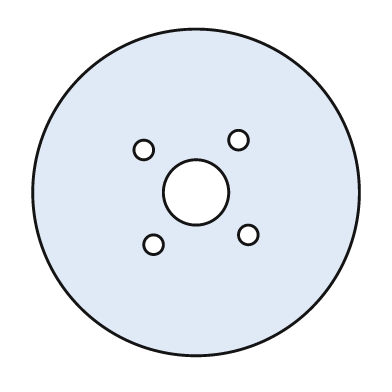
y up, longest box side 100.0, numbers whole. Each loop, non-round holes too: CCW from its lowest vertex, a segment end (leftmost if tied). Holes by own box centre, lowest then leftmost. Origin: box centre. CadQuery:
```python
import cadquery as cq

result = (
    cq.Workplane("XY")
    .moveTo(0.0, 0.0)
    .circle(50.0)
    .moveTo(-13.0, -16.0)
    .circle(3.0)
    .moveTo(16.0, -13.0)
    .circle(3.0)
    .moveTo(0.0, 0.0)
    .circle(10.0)
    .moveTo(-16.0, 13.0)
    .circle(3.0)
    .moveTo(13.0, 16.0)
    .circle(3.0)
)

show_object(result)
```